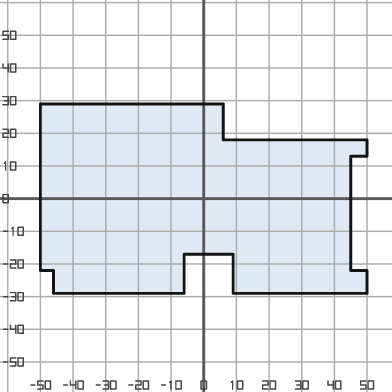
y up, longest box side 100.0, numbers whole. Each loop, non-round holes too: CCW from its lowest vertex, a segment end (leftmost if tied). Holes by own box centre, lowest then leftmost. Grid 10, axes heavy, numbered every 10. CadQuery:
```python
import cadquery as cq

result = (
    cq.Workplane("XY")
    .moveTo(-46.0, -29.0)
    .lineTo(-6.0, -29.0)
    .lineTo(-6.0, -17.0)
    .lineTo(9.0, -17.0)
    .lineTo(9.0, -29.0)
    .lineTo(50.0, -29.0)
    .lineTo(50.0, -22.0)
    .lineTo(45.0, -22.0)
    .lineTo(45.0, 13.0)
    .lineTo(50.0, 13.0)
    .lineTo(50.0, 18.0)
    .lineTo(6.0, 18.0)
    .lineTo(6.0, 29.0)
    .lineTo(-50.0, 29.0)
    .lineTo(-50.0, -22.0)
    .lineTo(-46.0, -22.0)
    .close()
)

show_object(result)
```